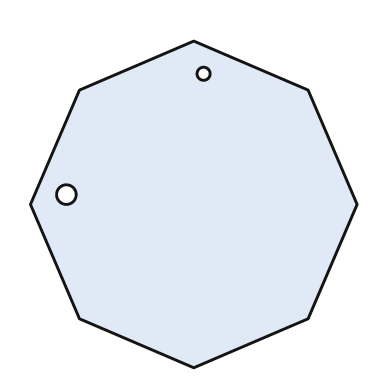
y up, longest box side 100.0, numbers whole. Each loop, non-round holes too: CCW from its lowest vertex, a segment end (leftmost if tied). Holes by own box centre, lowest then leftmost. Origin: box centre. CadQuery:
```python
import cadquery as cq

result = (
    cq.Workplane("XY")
    .moveTo(0.0, -50.0)
    .lineTo(35.0, -35.0)
    .lineTo(50.0, 0.0)
    .lineTo(35.0, 35.0)
    .lineTo(0.0, 50.0)
    .lineTo(-35.0, 35.0)
    .lineTo(-50.0, 0.0)
    .lineTo(-35.0, -35.0)
    .close()
    .moveTo(-39.0, 3.0)
    .circle(3.0)
    .moveTo(3.0, 40.0)
    .circle(2.0)
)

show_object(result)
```